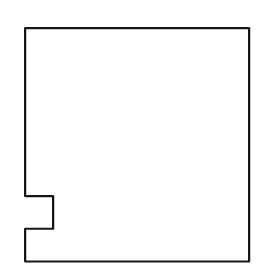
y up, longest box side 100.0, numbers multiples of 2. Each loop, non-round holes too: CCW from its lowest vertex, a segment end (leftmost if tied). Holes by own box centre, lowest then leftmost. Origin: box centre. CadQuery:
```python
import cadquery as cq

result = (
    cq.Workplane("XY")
    .moveTo(-48.0, -50.0)
    .lineTo(48.0, -50.0)
    .lineTo(48.0, 50.0)
    .lineTo(-48.0, 50.0)
    .lineTo(-48.0, -22.0)
    .lineTo(-36.0, -22.0)
    .lineTo(-36.0, -36.0)
    .lineTo(-48.0, -36.0)
    .close()
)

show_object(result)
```